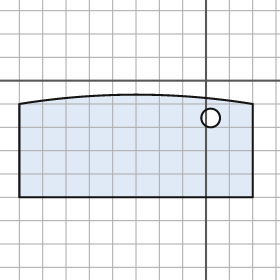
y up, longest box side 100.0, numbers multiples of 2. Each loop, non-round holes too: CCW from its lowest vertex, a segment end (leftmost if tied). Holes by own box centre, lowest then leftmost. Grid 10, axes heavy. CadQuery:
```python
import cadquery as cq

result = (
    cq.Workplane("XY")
    .moveTo(-80.0, -50.0)
    .lineTo(20.0, -50.0)
    .lineTo(20.0, -10.0)
    .threePointArc((-30.0, -6.0), (-80.0, -10.0))
    .close()
    .moveTo(2.0, -16.0)
    .circle(4.0)
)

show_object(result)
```